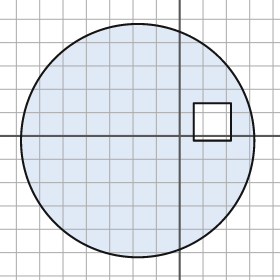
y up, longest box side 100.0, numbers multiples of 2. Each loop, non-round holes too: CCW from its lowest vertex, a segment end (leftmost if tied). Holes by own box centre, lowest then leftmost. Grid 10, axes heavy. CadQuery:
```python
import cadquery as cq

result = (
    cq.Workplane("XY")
    .moveTo(-18.0, -2.0)
    .circle(50.0)
    .moveTo(6.0, -2.0)
    .lineTo(22.0, -2.0)
    .lineTo(22.0, 14.0)
    .lineTo(6.0, 14.0)
    .close()
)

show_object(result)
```